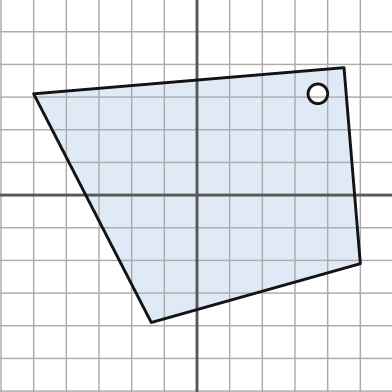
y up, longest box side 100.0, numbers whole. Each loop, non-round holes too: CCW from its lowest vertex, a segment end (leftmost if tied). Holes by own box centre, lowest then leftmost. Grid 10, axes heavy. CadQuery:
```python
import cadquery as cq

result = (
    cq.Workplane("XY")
    .moveTo(-14.0, -39.0)
    .lineTo(50.0, -21.0)
    .lineTo(45.0, 39.0)
    .lineTo(-50.0, 31.0)
    .close()
    .moveTo(37.0, 31.0)
    .circle(3.0)
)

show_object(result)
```